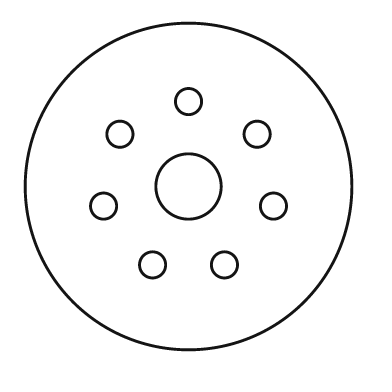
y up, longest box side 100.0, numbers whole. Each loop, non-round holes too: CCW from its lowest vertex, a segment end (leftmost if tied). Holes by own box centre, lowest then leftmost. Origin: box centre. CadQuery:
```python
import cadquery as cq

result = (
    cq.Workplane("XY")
    .moveTo(0.0, 0.0)
    .circle(50.0)
    .moveTo(-11.0, -24.0)
    .circle(4.0)
    .moveTo(11.0, -24.0)
    .circle(4.0)
    .moveTo(-26.0, -6.0)
    .circle(4.0)
    .moveTo(26.0, -6.0)
    .circle(4.0)
    .moveTo(0.0, 0.0)
    .circle(10.0)
    .moveTo(-21.0, 16.0)
    .circle(4.0)
    .moveTo(21.0, 16.0)
    .circle(4.0)
    .moveTo(0.0, 26.0)
    .circle(4.0)
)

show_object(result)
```